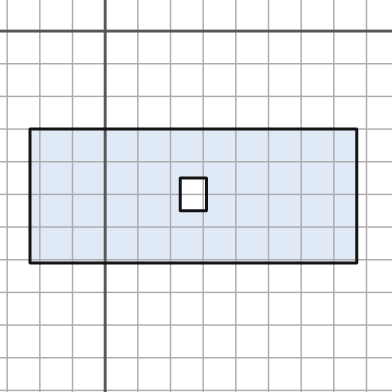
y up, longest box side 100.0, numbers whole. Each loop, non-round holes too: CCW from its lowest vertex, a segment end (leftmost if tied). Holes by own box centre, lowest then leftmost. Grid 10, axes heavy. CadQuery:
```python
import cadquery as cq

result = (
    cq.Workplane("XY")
    .moveTo(-23.0, -71.0)
    .lineTo(77.0, -71.0)
    .lineTo(77.0, -30.0)
    .lineTo(-23.0, -30.0)
    .close()
    .moveTo(23.0, -55.0)
    .lineTo(31.0, -55.0)
    .lineTo(31.0, -45.0)
    .lineTo(23.0, -45.0)
    .close()
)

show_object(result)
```